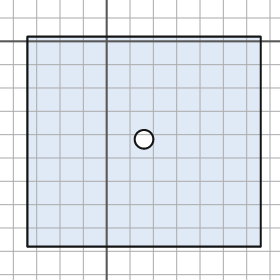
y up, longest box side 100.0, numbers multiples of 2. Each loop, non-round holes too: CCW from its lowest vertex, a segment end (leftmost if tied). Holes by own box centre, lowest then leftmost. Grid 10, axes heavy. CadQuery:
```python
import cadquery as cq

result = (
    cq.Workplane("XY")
    .moveTo(-34.0, -88.0)
    .lineTo(66.0, -88.0)
    .lineTo(66.0, 2.0)
    .lineTo(-34.0, 2.0)
    .close()
    .moveTo(16.0, -42.0)
    .circle(4.0)
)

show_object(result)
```